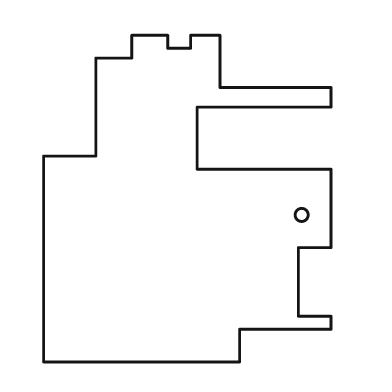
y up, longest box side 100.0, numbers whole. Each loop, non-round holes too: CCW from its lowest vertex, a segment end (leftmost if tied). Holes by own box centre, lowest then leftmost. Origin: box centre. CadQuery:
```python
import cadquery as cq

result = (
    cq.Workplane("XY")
    .moveTo(-44.0, -50.0)
    .lineTo(16.0, -50.0)
    .lineTo(16.0, -40.0)
    .lineTo(44.0, -40.0)
    .lineTo(44.0, -36.0)
    .lineTo(34.0, -36.0)
    .lineTo(34.0, -15.0)
    .lineTo(44.0, -15.0)
    .lineTo(44.0, 9.0)
    .lineTo(3.0, 9.0)
    .lineTo(3.0, 28.0)
    .lineTo(44.0, 28.0)
    .lineTo(44.0, 34.0)
    .lineTo(10.0, 34.0)
    .lineTo(10.0, 50.0)
    .lineTo(1.0, 50.0)
    .lineTo(1.0, 46.0)
    .lineTo(-6.0, 46.0)
    .lineTo(-6.0, 50.0)
    .lineTo(-17.0, 50.0)
    .lineTo(-17.0, 43.0)
    .lineTo(-28.0, 43.0)
    .lineTo(-28.0, 13.0)
    .lineTo(-44.0, 13.0)
    .close()
    .moveTo(35.0, -5.0)
    .circle(2.0)
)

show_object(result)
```